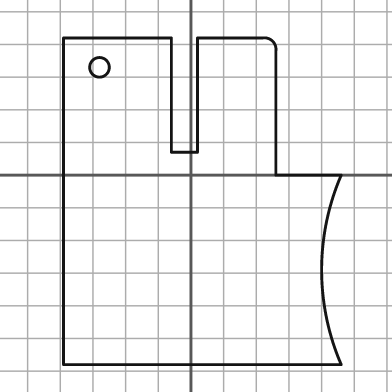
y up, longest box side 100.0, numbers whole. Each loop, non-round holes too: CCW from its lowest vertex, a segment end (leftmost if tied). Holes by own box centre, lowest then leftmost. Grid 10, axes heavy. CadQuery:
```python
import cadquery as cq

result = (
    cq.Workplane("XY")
    .moveTo(-39.0, -58.0)
    .lineTo(46.0, -58.0)
    .threePointArc((40.0, -29.0), (46.0, 0.0))
    .lineTo(26.0, 0.0)
    .lineTo(26.0, 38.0)
    .threePointArc((25.0, 41.0), (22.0, 42.0))
    .lineTo(2.0, 42.0)
    .lineTo(2.0, 7.0)
    .lineTo(-6.0, 7.0)
    .lineTo(-6.0, 42.0)
    .lineTo(-39.0, 42.0)
    .close()
    .moveTo(-28.0, 33.0)
    .circle(3.0)
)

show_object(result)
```